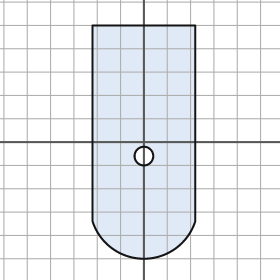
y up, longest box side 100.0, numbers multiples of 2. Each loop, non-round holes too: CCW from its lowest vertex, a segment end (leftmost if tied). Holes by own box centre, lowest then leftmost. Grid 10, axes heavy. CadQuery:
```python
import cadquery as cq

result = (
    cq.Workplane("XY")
    .moveTo(-22.0, -34.0)
    .threePointArc((0.0, -50.0), (22.0, -34.0))
    .lineTo(22.0, 50.0)
    .lineTo(-22.0, 50.0)
    .close()
    .moveTo(0.0, -6.0)
    .circle(4.0)
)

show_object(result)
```